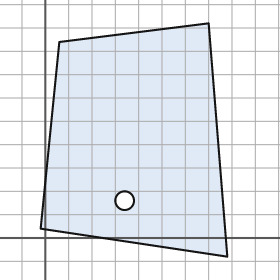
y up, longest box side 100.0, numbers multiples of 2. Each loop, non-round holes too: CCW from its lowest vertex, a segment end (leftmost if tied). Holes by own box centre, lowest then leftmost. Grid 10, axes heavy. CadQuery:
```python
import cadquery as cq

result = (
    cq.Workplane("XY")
    .moveTo(78.0, -8.0)
    .lineTo(70.0, 92.0)
    .lineTo(6.0, 84.0)
    .lineTo(-2.0, 4.0)
    .close()
    .moveTo(34.0, 16.0)
    .circle(4.0)
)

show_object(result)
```